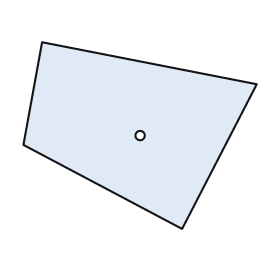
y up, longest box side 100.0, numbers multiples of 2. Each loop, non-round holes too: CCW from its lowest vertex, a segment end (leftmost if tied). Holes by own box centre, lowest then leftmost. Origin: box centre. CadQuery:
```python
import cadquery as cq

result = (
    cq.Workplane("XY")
    .moveTo(18.0, -40.0)
    .lineTo(50.0, 22.0)
    .lineTo(-42.0, 40.0)
    .lineTo(-50.0, -4.0)
    .close()
    .moveTo(0.0, 0.0)
    .circle(2.0)
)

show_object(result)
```